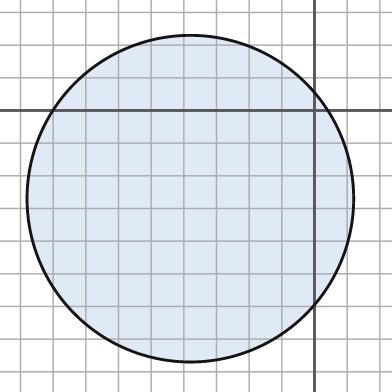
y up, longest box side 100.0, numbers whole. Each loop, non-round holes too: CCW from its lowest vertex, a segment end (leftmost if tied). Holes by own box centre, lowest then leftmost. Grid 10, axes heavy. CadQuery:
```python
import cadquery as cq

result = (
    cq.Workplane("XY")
    .moveTo(-38.0, -27.0)
    .circle(50.0)
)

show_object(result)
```